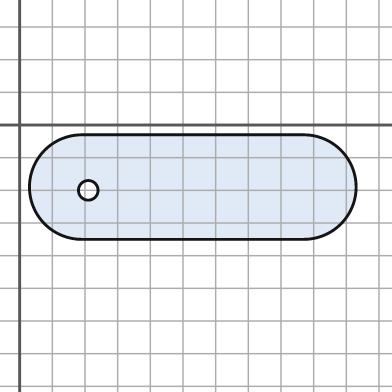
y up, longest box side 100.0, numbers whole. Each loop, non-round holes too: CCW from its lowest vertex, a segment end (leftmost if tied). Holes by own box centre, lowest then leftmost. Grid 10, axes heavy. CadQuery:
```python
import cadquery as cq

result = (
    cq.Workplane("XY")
    .moveTo(19.0, -35.0)
    .lineTo(87.0, -35.0)
    .threePointArc((103.0, -19.0), (87.0, -3.0))
    .lineTo(19.0, -3.0)
    .threePointArc((3.0, -19.0), (19.0, -35.0))
    .close()
    .moveTo(21.0, -20.0)
    .circle(3.0)
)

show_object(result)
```